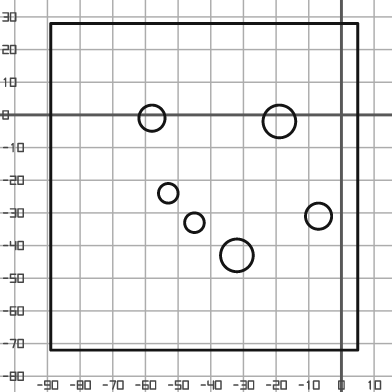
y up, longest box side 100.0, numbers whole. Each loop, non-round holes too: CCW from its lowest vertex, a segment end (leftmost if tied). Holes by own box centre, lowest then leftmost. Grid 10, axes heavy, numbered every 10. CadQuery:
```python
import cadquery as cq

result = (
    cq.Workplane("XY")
    .moveTo(-89.0, -72.0)
    .lineTo(5.0, -72.0)
    .lineTo(5.0, 28.0)
    .lineTo(-89.0, 28.0)
    .close()
    .moveTo(-32.0, -43.0)
    .circle(5.0)
    .moveTo(-45.0, -33.0)
    .circle(3.0)
    .moveTo(-7.0, -31.0)
    .circle(4.0)
    .moveTo(-53.0, -24.0)
    .circle(3.0)
    .moveTo(-19.0, -2.0)
    .circle(5.0)
    .moveTo(-58.0, -1.0)
    .circle(4.0)
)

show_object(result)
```